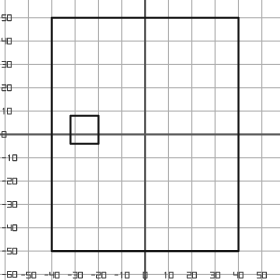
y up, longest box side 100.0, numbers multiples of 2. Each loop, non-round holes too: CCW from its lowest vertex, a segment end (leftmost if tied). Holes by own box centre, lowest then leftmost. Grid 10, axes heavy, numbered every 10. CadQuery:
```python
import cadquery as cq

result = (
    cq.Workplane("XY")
    .moveTo(-40.0, -50.0)
    .lineTo(40.0, -50.0)
    .lineTo(40.0, 50.0)
    .lineTo(-40.0, 50.0)
    .close()
    .moveTo(-32.0, -4.0)
    .lineTo(-20.0, -4.0)
    .lineTo(-20.0, 8.0)
    .lineTo(-32.0, 8.0)
    .close()
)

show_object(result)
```